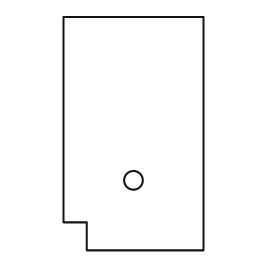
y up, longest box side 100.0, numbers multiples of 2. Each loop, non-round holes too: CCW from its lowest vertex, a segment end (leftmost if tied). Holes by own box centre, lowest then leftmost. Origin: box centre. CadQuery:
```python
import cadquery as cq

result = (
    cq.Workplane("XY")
    .moveTo(-20.0, -50.0)
    .lineTo(30.0, -50.0)
    .lineTo(30.0, 50.0)
    .lineTo(-30.0, 50.0)
    .lineTo(-30.0, -38.0)
    .lineTo(-20.0, -38.0)
    .close()
    .moveTo(0.0, -20.0)
    .circle(4.0)
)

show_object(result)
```